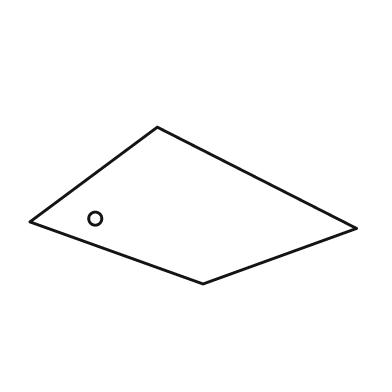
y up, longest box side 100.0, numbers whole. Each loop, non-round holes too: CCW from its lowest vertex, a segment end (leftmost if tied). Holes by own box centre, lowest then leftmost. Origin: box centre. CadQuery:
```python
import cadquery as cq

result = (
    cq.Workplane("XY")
    .moveTo(3.0, -24.0)
    .lineTo(50.0, -7.0)
    .lineTo(-11.0, 24.0)
    .lineTo(-50.0, -5.0)
    .close()
    .moveTo(-30.0, -4.0)
    .circle(2.0)
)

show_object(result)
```